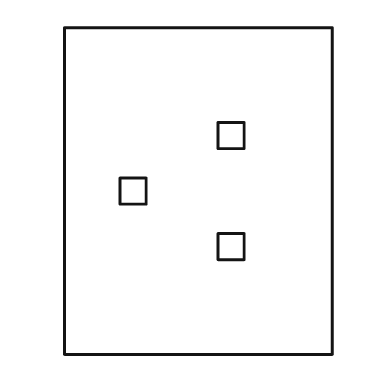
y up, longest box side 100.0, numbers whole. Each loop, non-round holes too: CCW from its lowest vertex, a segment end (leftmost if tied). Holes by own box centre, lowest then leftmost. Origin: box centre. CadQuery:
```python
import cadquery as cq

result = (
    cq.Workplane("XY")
    .moveTo(-41.0, -50.0)
    .lineTo(41.0, -50.0)
    .lineTo(41.0, 50.0)
    .lineTo(-41.0, 50.0)
    .close()
    .moveTo(6.0, -21.0)
    .lineTo(14.0, -21.0)
    .lineTo(14.0, -13.0)
    .lineTo(6.0, -13.0)
    .close()
    .moveTo(-24.0, -4.0)
    .lineTo(-16.0, -4.0)
    .lineTo(-16.0, 4.0)
    .lineTo(-24.0, 4.0)
    .close()
    .moveTo(6.0, 13.0)
    .lineTo(14.0, 13.0)
    .lineTo(14.0, 21.0)
    .lineTo(6.0, 21.0)
    .close()
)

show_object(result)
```